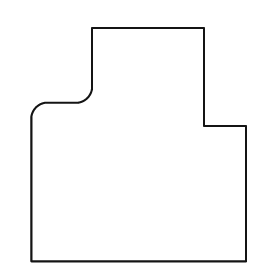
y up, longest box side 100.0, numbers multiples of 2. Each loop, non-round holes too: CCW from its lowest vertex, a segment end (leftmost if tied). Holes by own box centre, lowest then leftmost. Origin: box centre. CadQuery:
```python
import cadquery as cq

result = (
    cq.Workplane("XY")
    .moveTo(-46.0, -50.0)
    .lineTo(46.0, -50.0)
    .lineTo(46.0, 8.0)
    .lineTo(28.0, 8.0)
    .lineTo(28.0, 50.0)
    .lineTo(-20.0, 50.0)
    .lineTo(-20.0, 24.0)
    .threePointArc((-22.0, 20.0), (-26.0, 18.0))
    .lineTo(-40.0, 18.0)
    .threePointArc((-44.0, 16.0), (-46.0, 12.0))
    .close()
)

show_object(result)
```